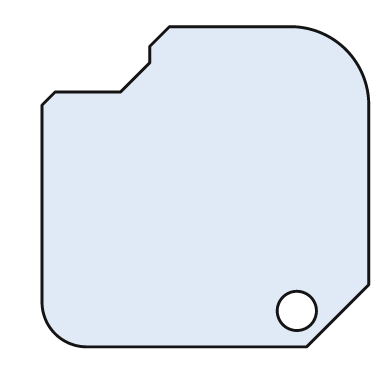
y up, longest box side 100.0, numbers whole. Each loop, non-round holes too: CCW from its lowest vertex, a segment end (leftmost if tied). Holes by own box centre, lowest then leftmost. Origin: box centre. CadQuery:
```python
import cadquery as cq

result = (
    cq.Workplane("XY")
    .moveTo(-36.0, -49.0)
    .lineTo(31.0, -49.0)
    .lineTo(50.0, -30.0)
    .lineTo(50.0, 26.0)
    .threePointArc((43.0, 42.0), (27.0, 49.0))
    .lineTo(-11.0, 49.0)
    .lineTo(-17.0, 43.0)
    .lineTo(-17.0, 38.0)
    .lineTo(-26.0, 29.0)
    .lineTo(-46.0, 29.0)
    .lineTo(-50.0, 25.0)
    .lineTo(-50.0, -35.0)
    .threePointArc((-46.0, -45.0), (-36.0, -49.0))
    .close()
    .moveTo(28.0, -38.0)
    .circle(6.0)
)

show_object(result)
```